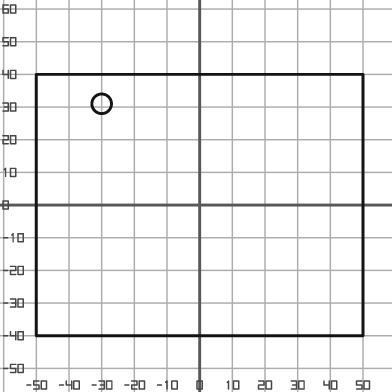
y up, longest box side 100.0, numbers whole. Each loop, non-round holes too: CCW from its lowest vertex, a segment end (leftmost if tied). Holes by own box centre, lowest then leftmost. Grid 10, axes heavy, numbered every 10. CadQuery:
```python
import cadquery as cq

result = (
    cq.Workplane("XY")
    .moveTo(-50.0, -40.0)
    .lineTo(50.0, -40.0)
    .lineTo(50.0, 40.0)
    .lineTo(-50.0, 40.0)
    .close()
    .moveTo(-30.0, 31.0)
    .circle(3.0)
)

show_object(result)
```